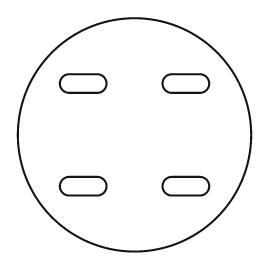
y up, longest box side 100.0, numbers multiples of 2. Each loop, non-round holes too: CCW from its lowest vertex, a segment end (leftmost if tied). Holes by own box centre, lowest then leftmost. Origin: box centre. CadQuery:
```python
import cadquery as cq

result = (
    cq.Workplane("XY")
    .moveTo(0.0, 0.0)
    .circle(50.0)
    .moveTo(-28.0, -26.0)
    .lineTo(-16.0, -26.0)
    .threePointArc((-12.0, -22.0), (-16.0, -18.0))
    .lineTo(-28.0, -18.0)
    .threePointArc((-32.0, -22.0), (-28.0, -26.0))
    .close()
    .moveTo(16.0, -26.0)
    .lineTo(28.0, -26.0)
    .threePointArc((32.0, -22.0), (28.0, -18.0))
    .lineTo(16.0, -18.0)
    .threePointArc((12.0, -22.0), (16.0, -26.0))
    .close()
    .moveTo(-28.0, 18.0)
    .lineTo(-16.0, 18.0)
    .threePointArc((-12.0, 22.0), (-16.0, 26.0))
    .lineTo(-28.0, 26.0)
    .threePointArc((-32.0, 22.0), (-28.0, 18.0))
    .close()
    .moveTo(16.0, 18.0)
    .lineTo(28.0, 18.0)
    .threePointArc((32.0, 22.0), (28.0, 26.0))
    .lineTo(16.0, 26.0)
    .threePointArc((12.0, 22.0), (16.0, 18.0))
    .close()
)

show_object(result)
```